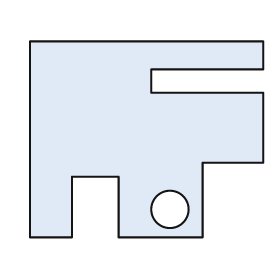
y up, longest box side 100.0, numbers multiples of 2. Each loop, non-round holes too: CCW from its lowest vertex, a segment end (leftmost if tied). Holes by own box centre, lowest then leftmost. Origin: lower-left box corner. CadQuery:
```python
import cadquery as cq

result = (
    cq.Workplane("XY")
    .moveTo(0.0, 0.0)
    .lineTo(18.0, 0.0)
    .lineTo(18.0, 26.0)
    .lineTo(38.0, 26.0)
    .lineTo(38.0, 0.0)
    .lineTo(74.0, 0.0)
    .lineTo(74.0, 32.0)
    .lineTo(100.0, 32.0)
    .lineTo(100.0, 62.0)
    .lineTo(52.0, 62.0)
    .lineTo(52.0, 72.0)
    .lineTo(100.0, 72.0)
    .lineTo(100.0, 84.0)
    .lineTo(0.0, 84.0)
    .close()
    .moveTo(60.0, 12.0)
    .circle(8.0)
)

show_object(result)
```